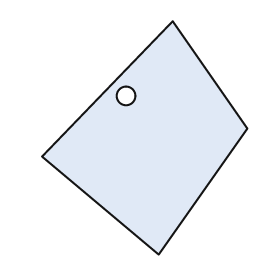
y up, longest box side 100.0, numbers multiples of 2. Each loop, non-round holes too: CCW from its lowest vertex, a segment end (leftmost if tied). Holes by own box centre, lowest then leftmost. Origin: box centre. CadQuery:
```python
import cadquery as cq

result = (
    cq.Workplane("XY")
    .moveTo(6.0, -50.0)
    .lineTo(44.0, 4.0)
    .lineTo(12.0, 50.0)
    .lineTo(-44.0, -8.0)
    .close()
    .moveTo(-8.0, 18.0)
    .circle(4.0)
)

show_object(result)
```